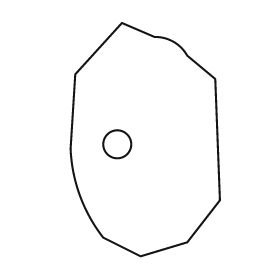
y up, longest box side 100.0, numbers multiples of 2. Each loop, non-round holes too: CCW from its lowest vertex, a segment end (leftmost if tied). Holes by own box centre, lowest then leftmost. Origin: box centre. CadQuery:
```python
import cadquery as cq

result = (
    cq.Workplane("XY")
    .moveTo(-2.0, -50.0)
    .lineTo(18.0, -44.0)
    .lineTo(32.0, -26.0)
    .lineTo(30.0, 26.0)
    .lineTo(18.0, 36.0)
    .threePointArc((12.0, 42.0), (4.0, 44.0))
    .lineTo(-10.0, 50.0)
    .lineTo(-30.0, 28.0)
    .lineTo(-32.0, -4.0)
    .threePointArc((-28.0, -24.0), (-18.0, -42.0))
    .close()
    .moveTo(-12.0, -2.0)
    .circle(6.0)
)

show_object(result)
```